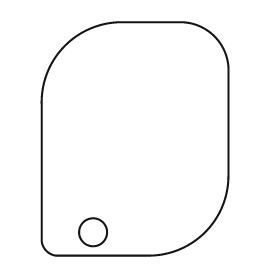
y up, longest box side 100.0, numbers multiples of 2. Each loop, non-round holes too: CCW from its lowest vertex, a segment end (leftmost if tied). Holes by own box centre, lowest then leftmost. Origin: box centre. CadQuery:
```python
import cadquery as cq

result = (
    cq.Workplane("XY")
    .moveTo(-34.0, -50.0)
    .lineTo(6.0, -50.0)
    .threePointArc((30.0, -40.0), (40.0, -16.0))
    .lineTo(40.0, 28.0)
    .threePointArc((34.0, 44.0), (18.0, 50.0))
    .lineTo(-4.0, 50.0)
    .threePointArc((-30.0, 40.0), (-40.0, 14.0))
    .lineTo(-40.0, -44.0)
    .threePointArc((-38.0, -48.0), (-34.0, -50.0))
    .close()
    .moveTo(-18.0, -40.0)
    .circle(6.0)
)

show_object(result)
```